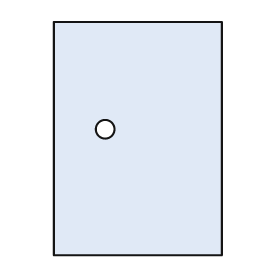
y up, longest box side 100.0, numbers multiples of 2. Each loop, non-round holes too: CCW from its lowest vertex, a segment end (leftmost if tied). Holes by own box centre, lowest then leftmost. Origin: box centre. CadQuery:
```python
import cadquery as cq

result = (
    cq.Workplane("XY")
    .moveTo(-36.0, -50.0)
    .lineTo(36.0, -50.0)
    .lineTo(36.0, 50.0)
    .lineTo(-36.0, 50.0)
    .close()
    .moveTo(-14.0, 4.0)
    .circle(4.0)
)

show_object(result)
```